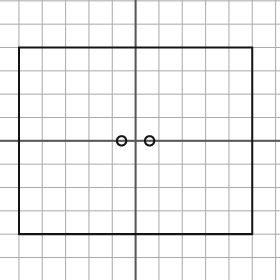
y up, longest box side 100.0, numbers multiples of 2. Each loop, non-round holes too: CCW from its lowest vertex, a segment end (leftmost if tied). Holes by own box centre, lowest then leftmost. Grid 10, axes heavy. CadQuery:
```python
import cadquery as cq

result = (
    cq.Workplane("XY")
    .moveTo(-50.0, -40.0)
    .lineTo(50.0, -40.0)
    .lineTo(50.0, 40.0)
    .lineTo(-50.0, 40.0)
    .close()
    .moveTo(-6.0, 0.0)
    .circle(2.0)
    .moveTo(6.0, 0.0)
    .circle(2.0)
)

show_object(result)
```